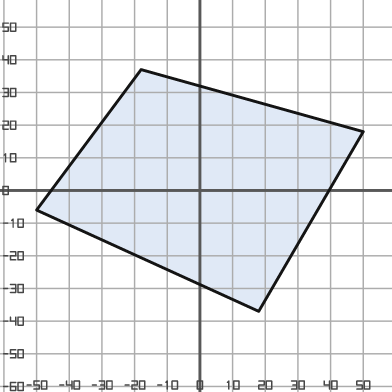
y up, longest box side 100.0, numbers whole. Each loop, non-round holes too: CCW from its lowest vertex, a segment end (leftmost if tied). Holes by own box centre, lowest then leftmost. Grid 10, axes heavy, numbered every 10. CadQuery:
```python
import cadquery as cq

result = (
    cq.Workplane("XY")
    .moveTo(18.0, -37.0)
    .lineTo(50.0, 18.0)
    .lineTo(-18.0, 37.0)
    .lineTo(-50.0, -6.0)
    .close()
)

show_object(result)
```